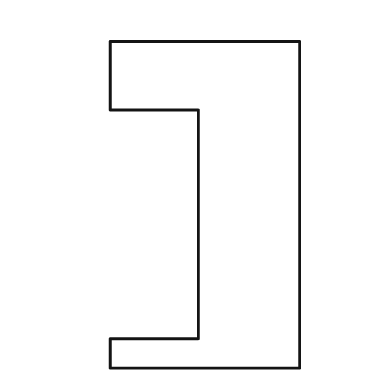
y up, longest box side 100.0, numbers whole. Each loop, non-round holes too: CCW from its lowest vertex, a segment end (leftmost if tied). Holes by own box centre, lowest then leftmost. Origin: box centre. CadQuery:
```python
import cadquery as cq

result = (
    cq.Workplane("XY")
    .moveTo(-29.0, -50.0)
    .lineTo(29.0, -50.0)
    .lineTo(29.0, 50.0)
    .lineTo(-29.0, 50.0)
    .lineTo(-29.0, 29.0)
    .lineTo(-2.0, 29.0)
    .lineTo(-2.0, -41.0)
    .lineTo(-29.0, -41.0)
    .close()
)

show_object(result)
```